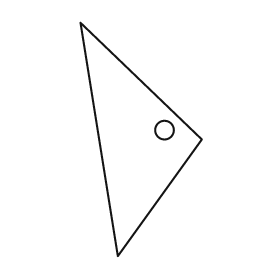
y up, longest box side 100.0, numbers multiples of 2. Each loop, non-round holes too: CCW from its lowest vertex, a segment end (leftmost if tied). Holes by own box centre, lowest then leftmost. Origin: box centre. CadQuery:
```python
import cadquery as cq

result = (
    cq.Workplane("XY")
    .moveTo(-10.0, -50.0)
    .lineTo(26.0, 0.0)
    .lineTo(-26.0, 50.0)
    .close()
    .moveTo(10.0, 4.0)
    .circle(4.0)
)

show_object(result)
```